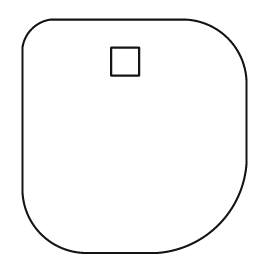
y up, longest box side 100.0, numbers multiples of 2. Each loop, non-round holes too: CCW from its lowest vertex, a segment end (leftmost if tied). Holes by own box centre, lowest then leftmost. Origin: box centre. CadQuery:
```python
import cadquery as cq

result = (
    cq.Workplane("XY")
    .moveTo(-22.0, -50.0)
    .lineTo(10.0, -50.0)
    .threePointArc((36.0, -38.0), (48.0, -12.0))
    .lineTo(48.0, 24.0)
    .threePointArc((40.0, 42.0), (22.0, 50.0))
    .lineTo(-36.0, 50.0)
    .threePointArc((-44.0, 46.0), (-48.0, 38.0))
    .lineTo(-48.0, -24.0)
    .threePointArc((-40.0, -42.0), (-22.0, -50.0))
    .close()
    .moveTo(-10.0, 26.0)
    .lineTo(2.0, 26.0)
    .lineTo(2.0, 38.0)
    .lineTo(-10.0, 38.0)
    .close()
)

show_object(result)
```